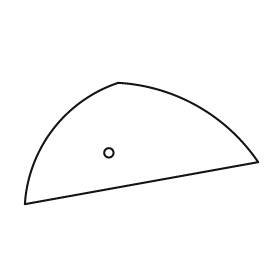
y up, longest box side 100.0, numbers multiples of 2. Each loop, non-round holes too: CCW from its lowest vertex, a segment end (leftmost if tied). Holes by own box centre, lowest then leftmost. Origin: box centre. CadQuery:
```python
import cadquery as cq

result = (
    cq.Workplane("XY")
    .moveTo(-50.0, -26.0)
    .lineTo(50.0, -8.0)
    .threePointArc((24.0, 16.0), (-10.0, 26.0))
    .threePointArc((-38.0, 6.0), (-50.0, -26.0))
    .close()
    .moveTo(-14.0, -4.0)
    .circle(2.0)
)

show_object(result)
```